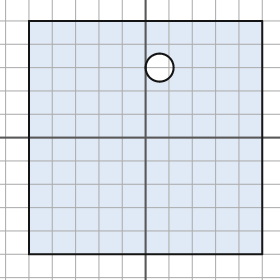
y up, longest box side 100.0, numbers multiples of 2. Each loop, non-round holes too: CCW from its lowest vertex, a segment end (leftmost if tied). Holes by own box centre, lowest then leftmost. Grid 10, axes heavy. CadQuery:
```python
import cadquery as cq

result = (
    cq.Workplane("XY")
    .moveTo(-50.0, -50.0)
    .lineTo(50.0, -50.0)
    .lineTo(50.0, 50.0)
    .lineTo(-50.0, 50.0)
    .close()
    .moveTo(6.0, 30.0)
    .circle(6.0)
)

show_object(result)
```